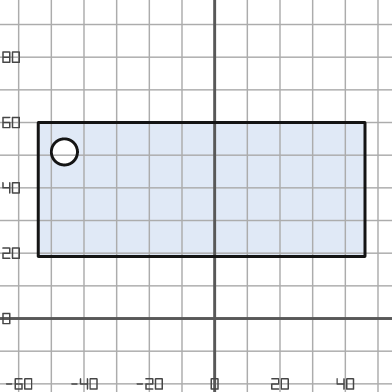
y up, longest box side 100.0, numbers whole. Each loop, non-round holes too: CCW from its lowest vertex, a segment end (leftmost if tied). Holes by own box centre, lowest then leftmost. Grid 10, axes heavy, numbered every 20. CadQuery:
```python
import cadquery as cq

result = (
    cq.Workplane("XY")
    .moveTo(-54.0, 19.0)
    .lineTo(46.0, 19.0)
    .lineTo(46.0, 60.0)
    .lineTo(-54.0, 60.0)
    .close()
    .moveTo(-46.0, 51.0)
    .circle(4.0)
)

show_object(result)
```